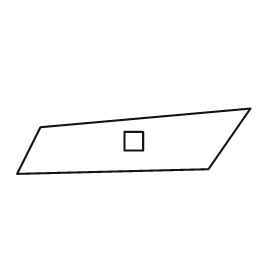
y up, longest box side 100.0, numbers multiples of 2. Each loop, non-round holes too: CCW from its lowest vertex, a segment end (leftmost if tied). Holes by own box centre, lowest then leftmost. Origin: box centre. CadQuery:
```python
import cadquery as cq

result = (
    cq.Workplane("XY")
    .moveTo(-50.0, -14.0)
    .lineTo(32.0, -12.0)
    .lineTo(50.0, 14.0)
    .lineTo(-40.0, 6.0)
    .close()
    .moveTo(-4.0, -4.0)
    .lineTo(4.0, -4.0)
    .lineTo(4.0, 4.0)
    .lineTo(-4.0, 4.0)
    .close()
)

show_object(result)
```